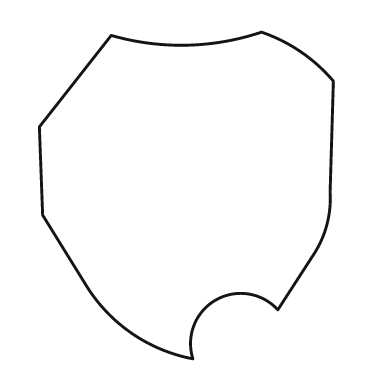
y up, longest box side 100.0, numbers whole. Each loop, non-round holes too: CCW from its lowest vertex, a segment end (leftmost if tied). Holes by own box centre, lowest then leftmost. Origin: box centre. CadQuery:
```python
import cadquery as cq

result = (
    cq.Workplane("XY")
    .moveTo(2.0, -50.0)
    .threePointArc((9.0, -32.0), (28.0, -35.0))
    .lineTo(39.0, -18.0)
    .threePointArc((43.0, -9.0), (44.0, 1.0))
    .lineTo(45.0, 35.0)
    .threePointArc((35.0, 44.0), (23.0, 50.0))
    .threePointArc((0.0, 46.0), (-23.0, 49.0))
    .lineTo(-45.0, 21.0)
    .lineTo(-44.0, -6.0)
    .lineTo(-31.0, -27.0)
    .threePointArc((-17.0, -42.0), (2.0, -50.0))
    .close()
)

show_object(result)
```